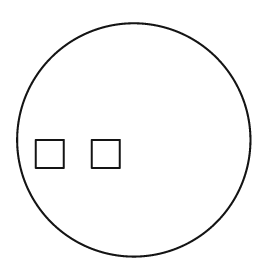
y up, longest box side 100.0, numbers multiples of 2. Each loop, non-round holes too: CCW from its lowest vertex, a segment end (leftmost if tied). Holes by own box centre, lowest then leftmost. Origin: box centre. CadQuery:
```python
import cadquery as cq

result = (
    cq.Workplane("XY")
    .moveTo(0.0, 0.0)
    .circle(50.0)
    .moveTo(-42.0, -12.0)
    .lineTo(-30.0, -12.0)
    .lineTo(-30.0, 0.0)
    .lineTo(-42.0, 0.0)
    .close()
    .moveTo(-18.0, -12.0)
    .lineTo(-6.0, -12.0)
    .lineTo(-6.0, 0.0)
    .lineTo(-18.0, 0.0)
    .close()
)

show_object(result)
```